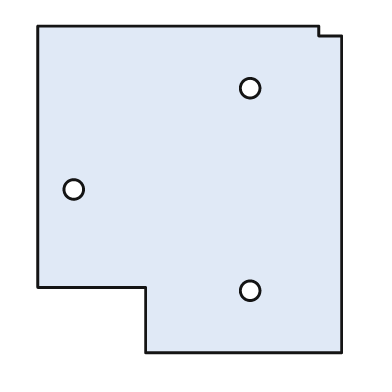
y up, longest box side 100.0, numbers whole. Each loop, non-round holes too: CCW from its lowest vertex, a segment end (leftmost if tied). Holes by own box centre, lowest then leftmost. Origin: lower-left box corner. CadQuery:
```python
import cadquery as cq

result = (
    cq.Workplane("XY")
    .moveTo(33.0, 0.0)
    .lineTo(93.0, 0.0)
    .lineTo(93.0, 97.0)
    .lineTo(86.0, 97.0)
    .lineTo(86.0, 100.0)
    .lineTo(0.0, 100.0)
    .lineTo(0.0, 20.0)
    .lineTo(33.0, 20.0)
    .close()
    .moveTo(65.0, 19.0)
    .circle(3.0)
    .moveTo(11.0, 50.0)
    .circle(3.0)
    .moveTo(65.0, 81.0)
    .circle(3.0)
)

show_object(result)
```